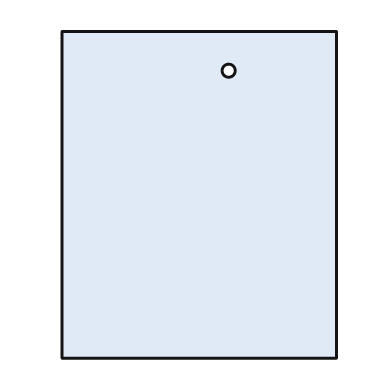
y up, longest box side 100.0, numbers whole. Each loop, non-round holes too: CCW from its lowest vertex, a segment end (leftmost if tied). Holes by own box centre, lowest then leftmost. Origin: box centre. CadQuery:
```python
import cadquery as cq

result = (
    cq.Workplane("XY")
    .moveTo(-42.0, -50.0)
    .lineTo(42.0, -50.0)
    .lineTo(42.0, 50.0)
    .lineTo(-42.0, 50.0)
    .close()
    .moveTo(9.0, 38.0)
    .circle(2.0)
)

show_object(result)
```